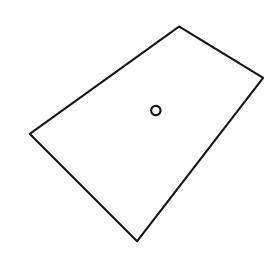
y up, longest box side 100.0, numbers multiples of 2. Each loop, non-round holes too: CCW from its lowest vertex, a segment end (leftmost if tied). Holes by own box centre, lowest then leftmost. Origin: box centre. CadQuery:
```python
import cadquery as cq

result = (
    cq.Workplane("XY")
    .moveTo(-4.0, -46.0)
    .lineTo(50.0, 24.0)
    .lineTo(14.0, 46.0)
    .lineTo(-50.0, 0.0)
    .close()
    .moveTo(4.0, 10.0)
    .circle(2.0)
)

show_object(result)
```